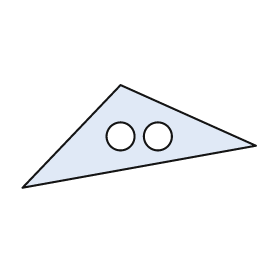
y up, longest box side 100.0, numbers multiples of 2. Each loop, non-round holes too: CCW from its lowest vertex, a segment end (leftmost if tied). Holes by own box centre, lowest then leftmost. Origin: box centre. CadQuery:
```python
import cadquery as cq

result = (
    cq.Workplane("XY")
    .moveTo(-50.0, -22.0)
    .lineTo(50.0, -4.0)
    .lineTo(-8.0, 22.0)
    .close()
    .moveTo(-8.0, 0.0)
    .circle(6.0)
    .moveTo(8.0, 0.0)
    .circle(6.0)
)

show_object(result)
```